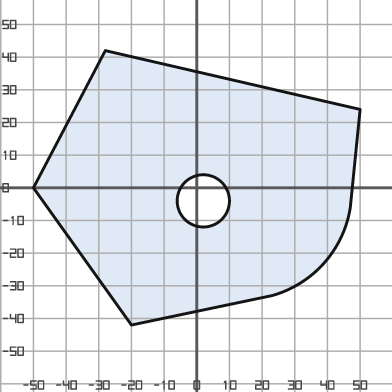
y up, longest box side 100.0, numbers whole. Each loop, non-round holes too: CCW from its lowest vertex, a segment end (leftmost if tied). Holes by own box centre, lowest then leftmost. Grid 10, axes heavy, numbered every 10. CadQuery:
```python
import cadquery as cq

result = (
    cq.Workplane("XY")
    .moveTo(-20.0, -42.0)
    .lineTo(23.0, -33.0)
    .threePointArc((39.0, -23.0), (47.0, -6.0))
    .lineTo(50.0, 24.0)
    .lineTo(-28.0, 42.0)
    .lineTo(-50.0, 0.0)
    .close()
    .moveTo(2.0, -4.0)
    .circle(8.0)
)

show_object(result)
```